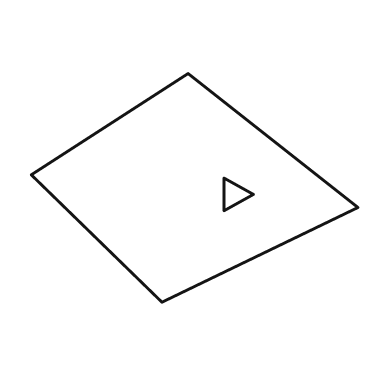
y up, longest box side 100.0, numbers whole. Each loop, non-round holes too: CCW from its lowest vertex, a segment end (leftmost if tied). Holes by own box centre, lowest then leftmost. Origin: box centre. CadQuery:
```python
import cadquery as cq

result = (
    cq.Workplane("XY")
    .moveTo(-10.0, -35.0)
    .lineTo(50.0, -6.0)
    .lineTo(-2.0, 35.0)
    .lineTo(-50.0, 4.0)
    .close()
    .moveTo(9.0, -7.0)
    .lineTo(18.0, -2.0)
    .lineTo(9.0, 3.0)
    .close()
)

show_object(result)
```